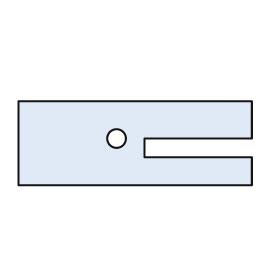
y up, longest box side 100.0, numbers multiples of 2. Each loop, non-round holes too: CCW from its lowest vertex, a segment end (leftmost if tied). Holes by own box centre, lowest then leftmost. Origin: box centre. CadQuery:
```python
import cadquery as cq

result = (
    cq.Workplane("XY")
    .moveTo(-50.0, -18.0)
    .lineTo(50.0, -18.0)
    .lineTo(50.0, -6.0)
    .lineTo(4.0, -6.0)
    .lineTo(4.0, 2.0)
    .lineTo(50.0, 2.0)
    .lineTo(50.0, 18.0)
    .lineTo(-50.0, 18.0)
    .close()
    .moveTo(-8.0, 2.0)
    .circle(4.0)
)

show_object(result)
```